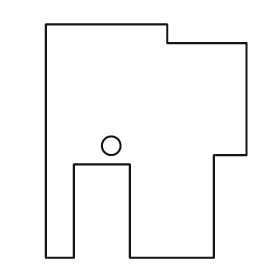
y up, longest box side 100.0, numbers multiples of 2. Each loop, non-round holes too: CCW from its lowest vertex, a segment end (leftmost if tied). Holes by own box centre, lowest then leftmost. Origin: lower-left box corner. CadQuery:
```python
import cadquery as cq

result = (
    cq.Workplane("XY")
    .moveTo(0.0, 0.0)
    .lineTo(12.0, 0.0)
    .lineTo(12.0, 40.0)
    .lineTo(36.0, 40.0)
    .lineTo(36.0, 0.0)
    .lineTo(72.0, 0.0)
    .lineTo(72.0, 44.0)
    .lineTo(86.0, 44.0)
    .lineTo(86.0, 92.0)
    .lineTo(52.0, 92.0)
    .lineTo(52.0, 100.0)
    .lineTo(0.0, 100.0)
    .close()
    .moveTo(28.0, 48.0)
    .circle(4.0)
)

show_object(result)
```